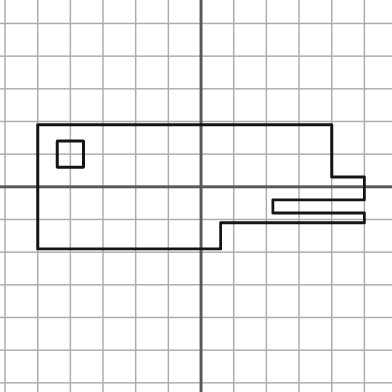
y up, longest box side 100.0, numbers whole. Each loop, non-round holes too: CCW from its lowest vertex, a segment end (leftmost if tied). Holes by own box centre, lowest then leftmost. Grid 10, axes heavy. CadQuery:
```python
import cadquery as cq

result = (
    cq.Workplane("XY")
    .moveTo(-50.0, -19.0)
    .lineTo(6.0, -19.0)
    .lineTo(6.0, -11.0)
    .lineTo(50.0, -11.0)
    .lineTo(50.0, -8.0)
    .lineTo(22.0, -8.0)
    .lineTo(22.0, -4.0)
    .lineTo(50.0, -4.0)
    .lineTo(50.0, 3.0)
    .lineTo(40.0, 3.0)
    .lineTo(40.0, 19.0)
    .lineTo(-50.0, 19.0)
    .close()
    .moveTo(-44.0, 6.0)
    .lineTo(-36.0, 6.0)
    .lineTo(-36.0, 14.0)
    .lineTo(-44.0, 14.0)
    .close()
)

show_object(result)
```